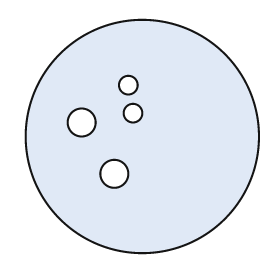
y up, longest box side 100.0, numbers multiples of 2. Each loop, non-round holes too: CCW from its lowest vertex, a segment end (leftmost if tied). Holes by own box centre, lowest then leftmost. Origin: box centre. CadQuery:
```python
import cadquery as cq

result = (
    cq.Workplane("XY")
    .moveTo(0.0, 0.0)
    .circle(50.0)
    .moveTo(-12.0, -16.0)
    .circle(6.0)
    .moveTo(-26.0, 6.0)
    .circle(6.0)
    .moveTo(-4.0, 10.0)
    .circle(4.0)
    .moveTo(-6.0, 22.0)
    .circle(4.0)
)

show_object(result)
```